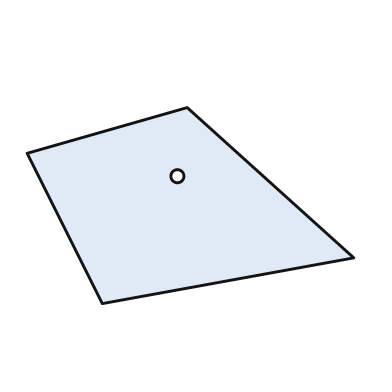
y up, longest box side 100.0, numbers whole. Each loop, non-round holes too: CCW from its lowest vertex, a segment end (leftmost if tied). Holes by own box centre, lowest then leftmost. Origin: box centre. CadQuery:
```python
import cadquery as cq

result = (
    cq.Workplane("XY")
    .moveTo(-27.0, -30.0)
    .lineTo(50.0, -16.0)
    .lineTo(-1.0, 30.0)
    .lineTo(-50.0, 16.0)
    .close()
    .moveTo(-4.0, 9.0)
    .circle(2.0)
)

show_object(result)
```